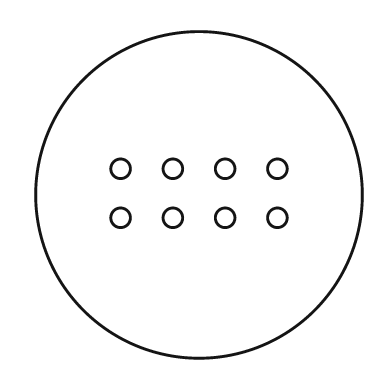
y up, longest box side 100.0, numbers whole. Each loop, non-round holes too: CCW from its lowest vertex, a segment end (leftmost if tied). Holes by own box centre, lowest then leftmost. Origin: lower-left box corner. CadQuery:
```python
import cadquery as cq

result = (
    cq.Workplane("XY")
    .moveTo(50.0, 50.0)
    .circle(50.0)
    .moveTo(26.0, 43.0)
    .circle(3.0)
    .moveTo(42.0, 43.0)
    .circle(3.0)
    .moveTo(58.0, 43.0)
    .circle(3.0)
    .moveTo(74.0, 43.0)
    .circle(3.0)
    .moveTo(26.0, 58.0)
    .circle(3.0)
    .moveTo(42.0, 58.0)
    .circle(3.0)
    .moveTo(58.0, 58.0)
    .circle(3.0)
    .moveTo(74.0, 58.0)
    .circle(3.0)
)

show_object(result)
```